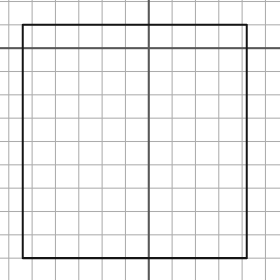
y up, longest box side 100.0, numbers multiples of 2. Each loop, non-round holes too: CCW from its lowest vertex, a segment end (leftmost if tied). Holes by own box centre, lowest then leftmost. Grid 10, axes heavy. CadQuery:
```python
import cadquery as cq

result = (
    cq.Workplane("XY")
    .moveTo(-54.0, -90.0)
    .lineTo(42.0, -90.0)
    .lineTo(42.0, 10.0)
    .lineTo(-54.0, 10.0)
    .close()
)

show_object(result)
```